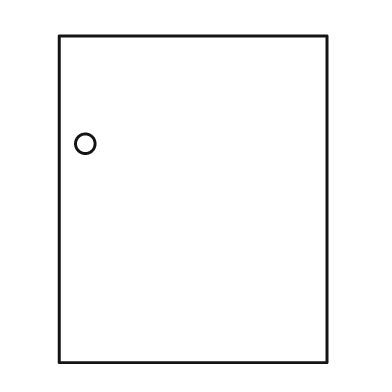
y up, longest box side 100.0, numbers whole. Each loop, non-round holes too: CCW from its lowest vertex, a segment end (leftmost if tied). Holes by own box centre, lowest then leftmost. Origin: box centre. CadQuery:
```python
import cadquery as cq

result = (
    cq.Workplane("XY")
    .moveTo(-41.0, -50.0)
    .lineTo(41.0, -50.0)
    .lineTo(41.0, 50.0)
    .lineTo(-41.0, 50.0)
    .close()
    .moveTo(-33.0, 17.0)
    .circle(3.0)
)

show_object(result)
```